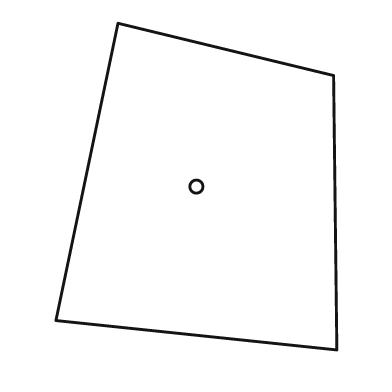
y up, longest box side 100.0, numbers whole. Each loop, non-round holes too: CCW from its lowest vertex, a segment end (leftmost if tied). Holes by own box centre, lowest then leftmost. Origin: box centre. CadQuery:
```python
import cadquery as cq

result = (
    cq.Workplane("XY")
    .moveTo(43.0, -50.0)
    .lineTo(42.0, 34.0)
    .lineTo(-24.0, 50.0)
    .lineTo(-43.0, -41.0)
    .close()
    .moveTo(0.0, 0.0)
    .circle(2.0)
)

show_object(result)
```